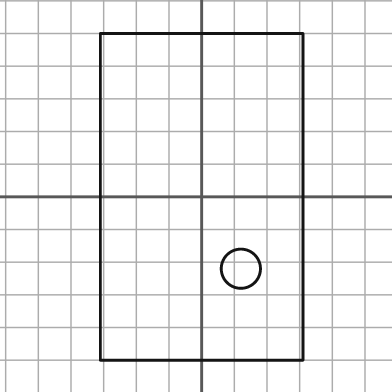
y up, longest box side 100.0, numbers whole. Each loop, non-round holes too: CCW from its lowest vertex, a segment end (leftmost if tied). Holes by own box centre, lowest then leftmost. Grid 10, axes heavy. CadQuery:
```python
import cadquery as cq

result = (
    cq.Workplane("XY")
    .moveTo(-31.0, -50.0)
    .lineTo(31.0, -50.0)
    .lineTo(31.0, 50.0)
    .lineTo(-31.0, 50.0)
    .close()
    .moveTo(12.0, -22.0)
    .circle(6.0)
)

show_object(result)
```